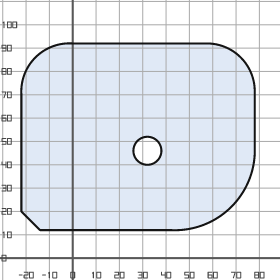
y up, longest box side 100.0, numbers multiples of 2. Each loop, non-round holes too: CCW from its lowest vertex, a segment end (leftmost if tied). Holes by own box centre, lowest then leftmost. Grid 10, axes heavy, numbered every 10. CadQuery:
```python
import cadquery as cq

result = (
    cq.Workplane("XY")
    .moveTo(-14.0, 12.0)
    .lineTo(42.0, 12.0)
    .threePointArc((68.0, 22.0), (78.0, 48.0))
    .lineTo(78.0, 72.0)
    .threePointArc((72.0, 86.0), (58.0, 92.0))
    .lineTo(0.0, 92.0)
    .threePointArc((-16.0, 86.0), (-22.0, 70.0))
    .lineTo(-22.0, 20.0)
    .close()
    .moveTo(32.0, 46.0)
    .circle(6.0)
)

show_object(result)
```